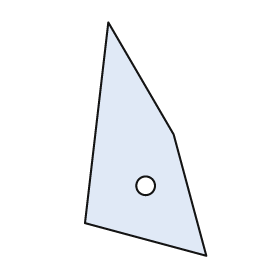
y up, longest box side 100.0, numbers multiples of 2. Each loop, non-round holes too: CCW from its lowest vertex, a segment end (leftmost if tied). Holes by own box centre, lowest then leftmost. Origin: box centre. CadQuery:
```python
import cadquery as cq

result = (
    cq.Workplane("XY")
    .moveTo(26.0, -50.0)
    .lineTo(12.0, 2.0)
    .lineTo(-16.0, 50.0)
    .lineTo(-26.0, -36.0)
    .close()
    .moveTo(0.0, -20.0)
    .circle(4.0)
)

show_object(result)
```